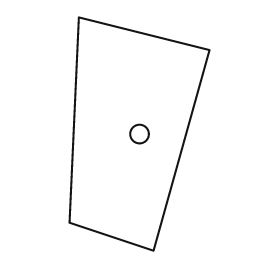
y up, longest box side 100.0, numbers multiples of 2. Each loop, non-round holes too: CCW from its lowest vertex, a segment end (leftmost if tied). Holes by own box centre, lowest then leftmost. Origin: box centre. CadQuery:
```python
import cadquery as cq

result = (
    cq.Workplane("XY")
    .moveTo(6.0, -50.0)
    .lineTo(30.0, 36.0)
    .lineTo(-26.0, 50.0)
    .lineTo(-30.0, -38.0)
    .close()
    .moveTo(0.0, 0.0)
    .circle(4.0)
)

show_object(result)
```